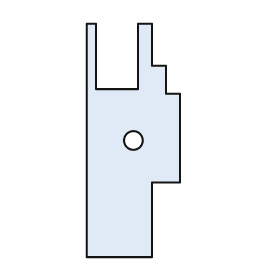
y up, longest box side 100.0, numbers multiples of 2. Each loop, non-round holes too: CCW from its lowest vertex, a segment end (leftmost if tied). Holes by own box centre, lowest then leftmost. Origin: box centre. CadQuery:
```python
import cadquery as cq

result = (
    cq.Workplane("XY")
    .moveTo(-20.0, -50.0)
    .lineTo(8.0, -50.0)
    .lineTo(8.0, -18.0)
    .lineTo(20.0, -18.0)
    .lineTo(20.0, 20.0)
    .lineTo(14.0, 20.0)
    .lineTo(14.0, 32.0)
    .lineTo(8.0, 32.0)
    .lineTo(8.0, 50.0)
    .lineTo(2.0, 50.0)
    .lineTo(2.0, 22.0)
    .lineTo(-16.0, 22.0)
    .lineTo(-16.0, 50.0)
    .lineTo(-20.0, 50.0)
    .close()
    .moveTo(0.0, 0.0)
    .circle(4.0)
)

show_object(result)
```